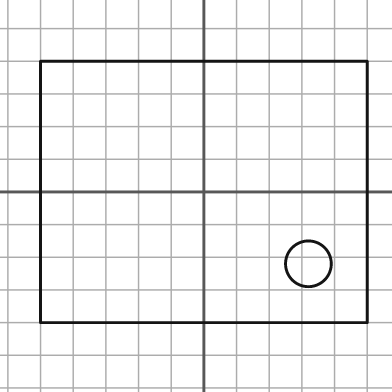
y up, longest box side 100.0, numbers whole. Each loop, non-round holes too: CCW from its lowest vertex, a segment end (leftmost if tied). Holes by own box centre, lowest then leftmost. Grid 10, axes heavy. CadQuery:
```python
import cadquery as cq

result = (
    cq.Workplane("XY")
    .moveTo(-50.0, -40.0)
    .lineTo(50.0, -40.0)
    .lineTo(50.0, 40.0)
    .lineTo(-50.0, 40.0)
    .close()
    .moveTo(32.0, -22.0)
    .circle(7.0)
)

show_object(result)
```